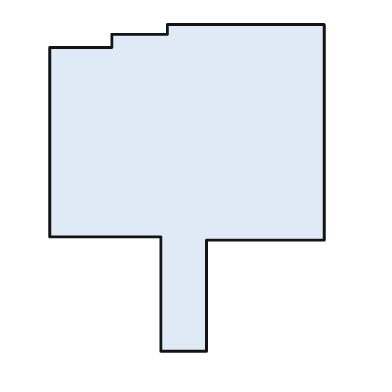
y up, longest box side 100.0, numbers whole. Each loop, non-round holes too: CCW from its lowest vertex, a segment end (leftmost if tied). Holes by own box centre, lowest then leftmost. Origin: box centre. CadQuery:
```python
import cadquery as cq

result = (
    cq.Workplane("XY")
    .moveTo(-8.0, -50.0)
    .lineTo(6.0, -50.0)
    .lineTo(6.0, -16.0)
    .lineTo(42.0, -16.0)
    .lineTo(42.0, 50.0)
    .lineTo(-6.0, 50.0)
    .lineTo(-6.0, 47.0)
    .lineTo(-23.0, 47.0)
    .lineTo(-23.0, 43.0)
    .lineTo(-42.0, 43.0)
    .lineTo(-42.0, -15.0)
    .lineTo(-8.0, -15.0)
    .close()
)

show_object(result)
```